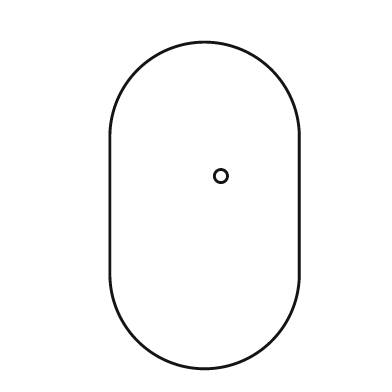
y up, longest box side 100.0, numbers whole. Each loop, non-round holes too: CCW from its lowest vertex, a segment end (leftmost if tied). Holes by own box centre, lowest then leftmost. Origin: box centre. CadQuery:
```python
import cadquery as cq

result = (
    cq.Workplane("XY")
    .moveTo(-29.0, -21.0)
    .threePointArc((0.0, -50.0), (29.0, -21.0))
    .lineTo(29.0, 21.0)
    .threePointArc((0.0, 50.0), (-29.0, 21.0))
    .close()
    .moveTo(5.0, 9.0)
    .circle(2.0)
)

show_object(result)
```